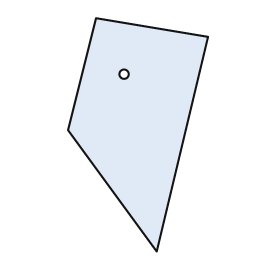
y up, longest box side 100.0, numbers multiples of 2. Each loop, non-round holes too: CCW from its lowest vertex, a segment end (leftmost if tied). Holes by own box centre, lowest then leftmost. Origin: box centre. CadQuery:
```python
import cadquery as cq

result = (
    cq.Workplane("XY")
    .moveTo(8.0, -50.0)
    .lineTo(30.0, 42.0)
    .lineTo(-18.0, 50.0)
    .lineTo(-30.0, 2.0)
    .close()
    .moveTo(-6.0, 26.0)
    .circle(2.0)
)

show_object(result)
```